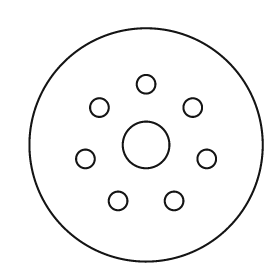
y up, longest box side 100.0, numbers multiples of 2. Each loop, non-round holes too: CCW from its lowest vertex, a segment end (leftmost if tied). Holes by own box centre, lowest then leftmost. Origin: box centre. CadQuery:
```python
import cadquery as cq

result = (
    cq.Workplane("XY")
    .moveTo(0.0, 0.0)
    .circle(50.0)
    .moveTo(-12.0, -24.0)
    .circle(4.0)
    .moveTo(12.0, -24.0)
    .circle(4.0)
    .moveTo(-26.0, -6.0)
    .circle(4.0)
    .moveTo(26.0, -6.0)
    .circle(4.0)
    .moveTo(0.0, 0.0)
    .circle(10.0)
    .moveTo(-20.0, 16.0)
    .circle(4.0)
    .moveTo(20.0, 16.0)
    .circle(4.0)
    .moveTo(0.0, 26.0)
    .circle(4.0)
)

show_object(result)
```